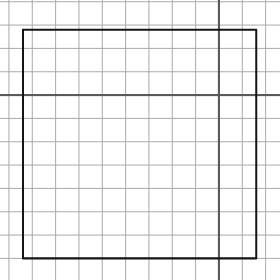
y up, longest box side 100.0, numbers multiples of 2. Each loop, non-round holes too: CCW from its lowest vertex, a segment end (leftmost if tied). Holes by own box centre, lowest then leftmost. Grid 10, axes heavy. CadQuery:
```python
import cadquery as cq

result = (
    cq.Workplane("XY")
    .moveTo(-84.0, -70.0)
    .lineTo(16.0, -70.0)
    .lineTo(16.0, 28.0)
    .lineTo(-84.0, 28.0)
    .close()
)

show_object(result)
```